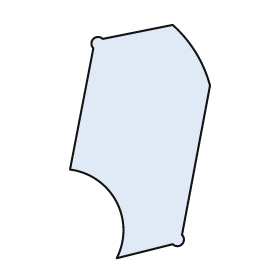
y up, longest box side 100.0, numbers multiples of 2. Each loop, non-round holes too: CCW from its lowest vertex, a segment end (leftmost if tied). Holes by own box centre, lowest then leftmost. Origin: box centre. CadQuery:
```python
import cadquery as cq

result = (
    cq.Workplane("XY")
    .moveTo(-10.0, -50.0)
    .lineTo(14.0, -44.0)
    .threePointArc((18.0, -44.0), (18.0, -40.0))
    .lineTo(30.0, 24.0)
    .threePointArc((24.0, 38.0), (14.0, 50.0))
    .lineTo(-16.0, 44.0)
    .threePointArc((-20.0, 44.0), (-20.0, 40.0))
    .lineTo(-30.0, -12.0)
    .threePointArc((-10.0, -26.0), (-10.0, -50.0))
    .close()
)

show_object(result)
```